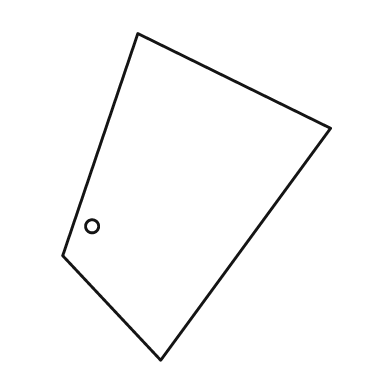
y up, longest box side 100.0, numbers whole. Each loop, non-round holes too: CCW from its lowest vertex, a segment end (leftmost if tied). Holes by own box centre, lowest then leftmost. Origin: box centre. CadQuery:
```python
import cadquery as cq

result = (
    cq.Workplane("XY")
    .moveTo(-11.0, -50.0)
    .lineTo(41.0, 21.0)
    .lineTo(-18.0, 50.0)
    .lineTo(-41.0, -18.0)
    .close()
    .moveTo(-32.0, -9.0)
    .circle(2.0)
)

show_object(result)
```